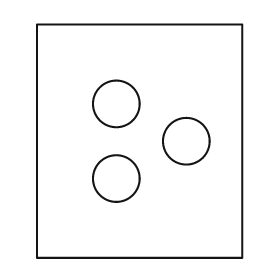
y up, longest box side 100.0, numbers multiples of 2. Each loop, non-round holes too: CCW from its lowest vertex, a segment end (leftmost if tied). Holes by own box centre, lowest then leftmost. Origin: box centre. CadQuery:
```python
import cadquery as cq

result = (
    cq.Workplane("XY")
    .moveTo(-44.0, -50.0)
    .lineTo(44.0, -50.0)
    .lineTo(44.0, 50.0)
    .lineTo(-44.0, 50.0)
    .close()
    .moveTo(-10.0, -16.0)
    .circle(10.0)
    .moveTo(20.0, 0.0)
    .circle(10.0)
    .moveTo(-10.0, 16.0)
    .circle(10.0)
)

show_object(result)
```